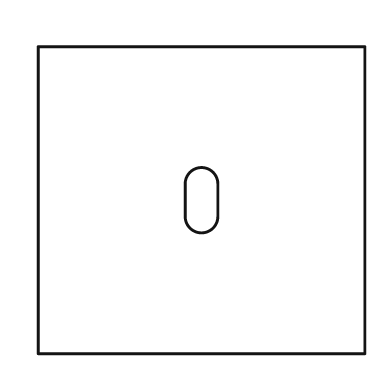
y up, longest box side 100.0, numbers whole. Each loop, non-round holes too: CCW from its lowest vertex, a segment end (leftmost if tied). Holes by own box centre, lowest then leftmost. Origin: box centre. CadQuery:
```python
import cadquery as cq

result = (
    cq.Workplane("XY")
    .moveTo(-50.0, -47.0)
    .lineTo(50.0, -47.0)
    .lineTo(50.0, 47.0)
    .lineTo(-50.0, 47.0)
    .close()
    .moveTo(-5.0, -5.0)
    .threePointArc((0.0, -10.0), (5.0, -5.0))
    .lineTo(5.0, 5.0)
    .threePointArc((0.0, 10.0), (-5.0, 5.0))
    .close()
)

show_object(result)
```